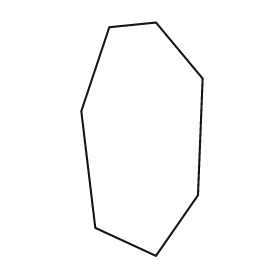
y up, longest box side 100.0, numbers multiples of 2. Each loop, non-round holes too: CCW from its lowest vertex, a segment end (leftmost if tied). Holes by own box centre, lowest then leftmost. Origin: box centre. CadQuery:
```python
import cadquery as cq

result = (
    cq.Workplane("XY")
    .moveTo(6.0, -50.0)
    .lineTo(24.0, -24.0)
    .lineTo(26.0, 26.0)
    .lineTo(6.0, 50.0)
    .lineTo(-14.0, 48.0)
    .lineTo(-26.0, 12.0)
    .lineTo(-20.0, -38.0)
    .close()
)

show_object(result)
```